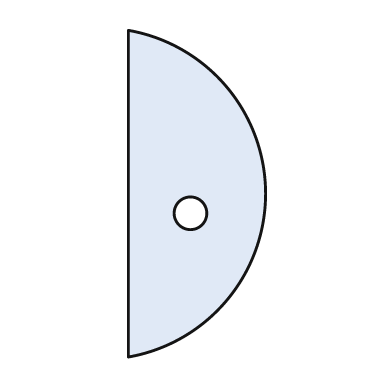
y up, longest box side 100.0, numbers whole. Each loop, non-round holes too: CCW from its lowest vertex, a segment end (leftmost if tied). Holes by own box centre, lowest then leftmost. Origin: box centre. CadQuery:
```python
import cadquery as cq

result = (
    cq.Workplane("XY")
    .moveTo(-21.0, -50.0)
    .threePointArc((21.0, 0.0), (-21.0, 50.0))
    .close()
    .moveTo(-2.0, -6.0)
    .circle(5.0)
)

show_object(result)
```